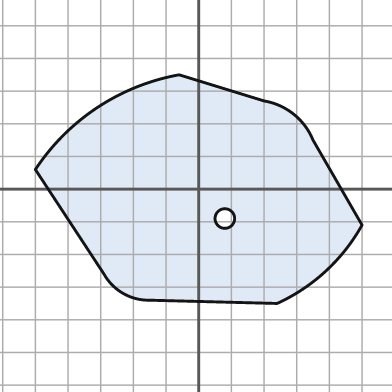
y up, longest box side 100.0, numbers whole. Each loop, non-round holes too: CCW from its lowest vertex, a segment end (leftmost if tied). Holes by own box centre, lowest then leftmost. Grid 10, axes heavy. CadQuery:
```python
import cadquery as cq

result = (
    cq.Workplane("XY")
    .moveTo(24.0, -35.0)
    .threePointArc((39.0, -25.0), (50.0, -11.0))
    .lineTo(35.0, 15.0)
    .threePointArc((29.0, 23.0), (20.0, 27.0))
    .lineTo(-6.0, 35.0)
    .threePointArc((-31.0, 25.0), (-50.0, 6.0))
    .lineTo(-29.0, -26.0)
    .threePointArc((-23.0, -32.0), (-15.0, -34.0))
    .close()
    .moveTo(8.0, -9.0)
    .circle(3.0)
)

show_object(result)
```